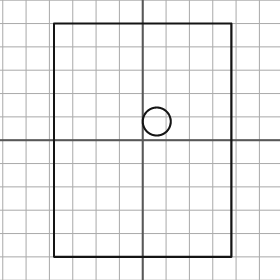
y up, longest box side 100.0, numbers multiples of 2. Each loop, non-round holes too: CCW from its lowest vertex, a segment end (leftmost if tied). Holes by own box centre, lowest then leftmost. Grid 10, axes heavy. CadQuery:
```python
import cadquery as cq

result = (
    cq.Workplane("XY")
    .moveTo(-38.0, -50.0)
    .lineTo(38.0, -50.0)
    .lineTo(38.0, 50.0)
    .lineTo(-38.0, 50.0)
    .close()
    .moveTo(6.0, 8.0)
    .circle(6.0)
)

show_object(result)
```